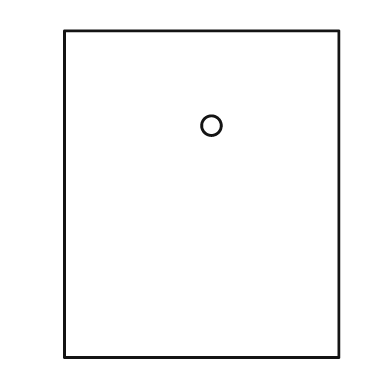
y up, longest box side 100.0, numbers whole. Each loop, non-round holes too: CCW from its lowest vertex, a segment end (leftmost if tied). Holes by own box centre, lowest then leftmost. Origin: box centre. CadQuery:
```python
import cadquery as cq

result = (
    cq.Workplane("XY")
    .moveTo(-42.0, -50.0)
    .lineTo(42.0, -50.0)
    .lineTo(42.0, 50.0)
    .lineTo(-42.0, 50.0)
    .close()
    .moveTo(3.0, 21.0)
    .circle(3.0)
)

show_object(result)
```